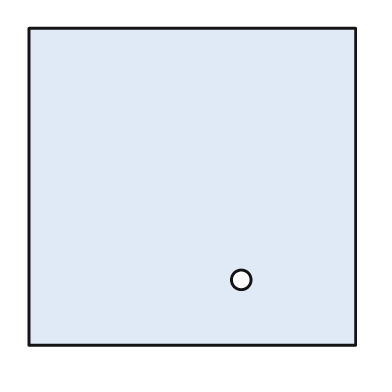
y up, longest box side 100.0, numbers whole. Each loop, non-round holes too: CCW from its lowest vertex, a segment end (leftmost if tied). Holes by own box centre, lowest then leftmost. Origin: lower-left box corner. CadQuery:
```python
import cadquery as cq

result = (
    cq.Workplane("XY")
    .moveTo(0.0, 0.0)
    .lineTo(100.0, 0.0)
    .lineTo(100.0, 97.0)
    .lineTo(0.0, 97.0)
    .close()
    .moveTo(65.0, 20.0)
    .circle(3.0)
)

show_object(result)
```